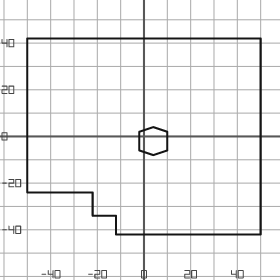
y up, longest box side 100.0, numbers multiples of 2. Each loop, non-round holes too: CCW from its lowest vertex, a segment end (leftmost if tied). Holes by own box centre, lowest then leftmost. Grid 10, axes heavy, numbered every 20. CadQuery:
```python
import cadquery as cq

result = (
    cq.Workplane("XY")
    .moveTo(-12.0, -42.0)
    .lineTo(50.0, -42.0)
    .lineTo(50.0, 42.0)
    .lineTo(-50.0, 42.0)
    .lineTo(-50.0, -24.0)
    .lineTo(-22.0, -24.0)
    .lineTo(-22.0, -34.0)
    .lineTo(-12.0, -34.0)
    .close()
    .moveTo(4.0, -8.0)
    .lineTo(10.0, -6.0)
    .lineTo(10.0, 2.0)
    .lineTo(4.0, 4.0)
    .lineTo(-2.0, 2.0)
    .lineTo(-2.0, -6.0)
    .close()
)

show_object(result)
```